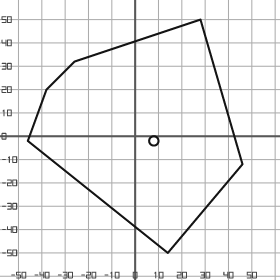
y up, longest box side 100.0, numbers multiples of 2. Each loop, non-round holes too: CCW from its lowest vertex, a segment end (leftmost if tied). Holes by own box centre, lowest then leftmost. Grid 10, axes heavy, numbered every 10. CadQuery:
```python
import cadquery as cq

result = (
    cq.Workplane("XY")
    .moveTo(14.0, -50.0)
    .lineTo(46.0, -12.0)
    .lineTo(28.0, 50.0)
    .lineTo(-26.0, 32.0)
    .lineTo(-38.0, 20.0)
    .lineTo(-46.0, -2.0)
    .close()
    .moveTo(8.0, -2.0)
    .circle(2.0)
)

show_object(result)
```